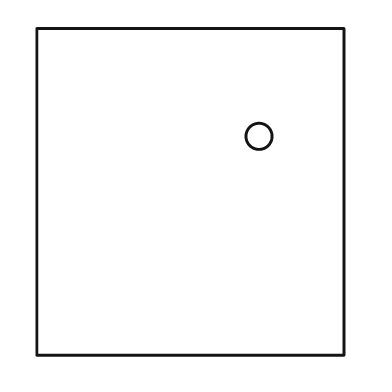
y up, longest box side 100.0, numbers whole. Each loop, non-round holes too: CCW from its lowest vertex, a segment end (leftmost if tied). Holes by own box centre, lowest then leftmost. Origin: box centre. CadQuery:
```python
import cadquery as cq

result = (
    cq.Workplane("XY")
    .moveTo(-47.0, -50.0)
    .lineTo(47.0, -50.0)
    .lineTo(47.0, 50.0)
    .lineTo(-47.0, 50.0)
    .close()
    .moveTo(21.0, 17.0)
    .circle(4.0)
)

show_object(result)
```